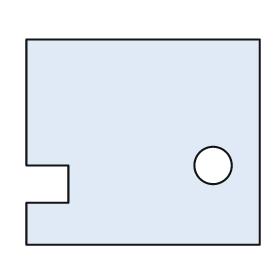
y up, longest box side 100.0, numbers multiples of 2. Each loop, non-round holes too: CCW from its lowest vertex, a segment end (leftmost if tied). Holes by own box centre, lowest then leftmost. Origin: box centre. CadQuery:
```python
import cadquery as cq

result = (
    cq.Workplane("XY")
    .moveTo(-50.0, -44.0)
    .lineTo(50.0, -44.0)
    .lineTo(50.0, 44.0)
    .lineTo(-50.0, 44.0)
    .lineTo(-50.0, -10.0)
    .lineTo(-32.0, -10.0)
    .lineTo(-32.0, -26.0)
    .lineTo(-50.0, -26.0)
    .close()
    .moveTo(30.0, -10.0)
    .circle(8.0)
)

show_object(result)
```